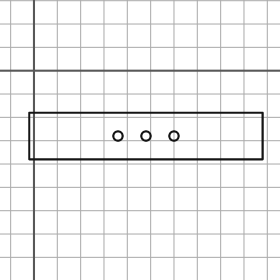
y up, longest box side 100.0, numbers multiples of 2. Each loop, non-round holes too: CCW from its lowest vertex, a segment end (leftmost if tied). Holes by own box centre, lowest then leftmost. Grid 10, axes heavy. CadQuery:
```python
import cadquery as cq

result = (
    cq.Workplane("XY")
    .moveTo(-2.0, -38.0)
    .lineTo(98.0, -38.0)
    .lineTo(98.0, -18.0)
    .lineTo(-2.0, -18.0)
    .close()
    .moveTo(36.0, -28.0)
    .circle(2.0)
    .moveTo(48.0, -28.0)
    .circle(2.0)
    .moveTo(60.0, -28.0)
    .circle(2.0)
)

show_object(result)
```